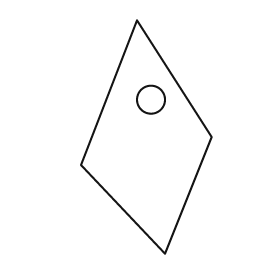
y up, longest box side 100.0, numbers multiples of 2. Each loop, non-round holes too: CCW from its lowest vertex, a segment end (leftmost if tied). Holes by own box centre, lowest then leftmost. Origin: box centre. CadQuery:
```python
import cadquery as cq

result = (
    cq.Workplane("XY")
    .moveTo(8.0, -50.0)
    .lineTo(28.0, 0.0)
    .lineTo(-4.0, 50.0)
    .lineTo(-28.0, -12.0)
    .close()
    .moveTo(2.0, 16.0)
    .circle(6.0)
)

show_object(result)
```